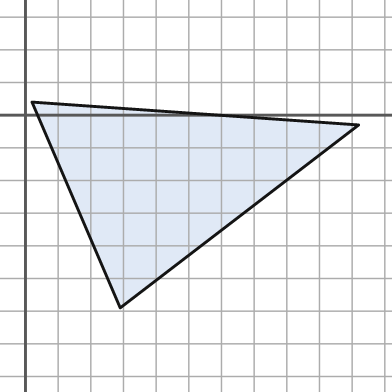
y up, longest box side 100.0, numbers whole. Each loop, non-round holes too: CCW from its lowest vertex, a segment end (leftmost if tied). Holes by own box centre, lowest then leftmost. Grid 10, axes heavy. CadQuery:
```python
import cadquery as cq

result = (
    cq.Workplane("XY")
    .moveTo(29.0, -59.0)
    .lineTo(102.0, -3.0)
    .lineTo(2.0, 4.0)
    .close()
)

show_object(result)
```